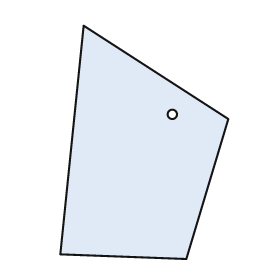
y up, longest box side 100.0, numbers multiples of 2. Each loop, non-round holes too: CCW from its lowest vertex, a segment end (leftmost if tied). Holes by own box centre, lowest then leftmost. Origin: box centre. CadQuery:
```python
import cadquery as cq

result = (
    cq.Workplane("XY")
    .moveTo(18.0, -50.0)
    .lineTo(36.0, 10.0)
    .lineTo(-26.0, 50.0)
    .lineTo(-36.0, -48.0)
    .close()
    .moveTo(12.0, 12.0)
    .circle(2.0)
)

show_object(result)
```